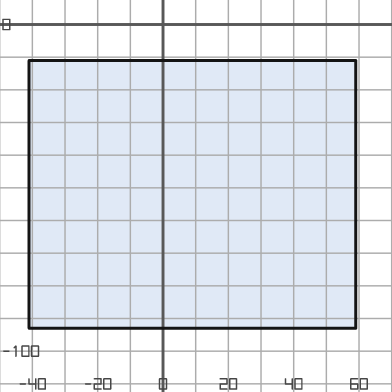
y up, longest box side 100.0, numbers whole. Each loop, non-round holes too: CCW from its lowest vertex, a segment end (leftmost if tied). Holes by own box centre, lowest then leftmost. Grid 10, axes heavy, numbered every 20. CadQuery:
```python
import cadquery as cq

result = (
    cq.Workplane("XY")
    .moveTo(-41.0, -93.0)
    .lineTo(59.0, -93.0)
    .lineTo(59.0, -11.0)
    .lineTo(-41.0, -11.0)
    .close()
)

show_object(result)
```